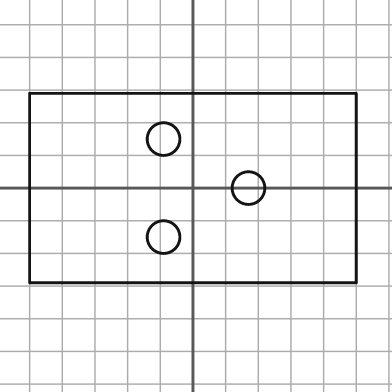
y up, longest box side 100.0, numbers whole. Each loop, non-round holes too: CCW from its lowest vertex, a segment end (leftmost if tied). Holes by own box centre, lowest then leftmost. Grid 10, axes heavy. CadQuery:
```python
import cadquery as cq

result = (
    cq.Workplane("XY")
    .moveTo(-50.0, -29.0)
    .lineTo(50.0, -29.0)
    .lineTo(50.0, 29.0)
    .lineTo(-50.0, 29.0)
    .close()
    .moveTo(-9.0, -15.0)
    .circle(5.0)
    .moveTo(17.0, 0.0)
    .circle(5.0)
    .moveTo(-9.0, 15.0)
    .circle(5.0)
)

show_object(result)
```